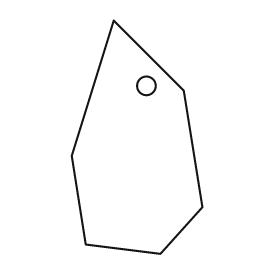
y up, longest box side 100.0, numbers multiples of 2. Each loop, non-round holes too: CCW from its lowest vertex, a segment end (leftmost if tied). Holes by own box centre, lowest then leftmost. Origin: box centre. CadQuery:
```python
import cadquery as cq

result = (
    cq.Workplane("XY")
    .moveTo(10.0, -50.0)
    .lineTo(28.0, -30.0)
    .lineTo(20.0, 20.0)
    .lineTo(-10.0, 50.0)
    .lineTo(-28.0, -8.0)
    .lineTo(-22.0, -46.0)
    .close()
    .moveTo(4.0, 22.0)
    .circle(4.0)
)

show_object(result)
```